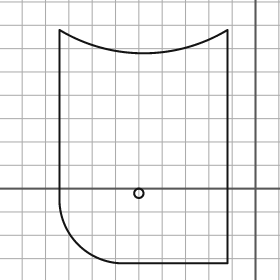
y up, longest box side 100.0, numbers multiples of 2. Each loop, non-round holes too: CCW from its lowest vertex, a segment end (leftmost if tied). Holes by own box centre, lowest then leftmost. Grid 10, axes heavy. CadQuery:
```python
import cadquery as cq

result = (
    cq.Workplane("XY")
    .moveTo(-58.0, -32.0)
    .lineTo(-12.0, -32.0)
    .lineTo(-12.0, 68.0)
    .threePointArc((-48.0, 58.0), (-84.0, 68.0))
    .lineTo(-84.0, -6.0)
    .threePointArc((-76.0, -24.0), (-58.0, -32.0))
    .close()
    .moveTo(-50.0, -2.0)
    .circle(2.0)
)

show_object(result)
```